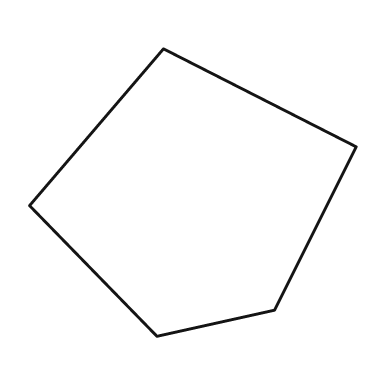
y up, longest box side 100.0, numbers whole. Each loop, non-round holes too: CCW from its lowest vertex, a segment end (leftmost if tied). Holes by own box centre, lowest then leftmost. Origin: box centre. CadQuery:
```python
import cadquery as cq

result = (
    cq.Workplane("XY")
    .moveTo(-11.0, -44.0)
    .lineTo(25.0, -36.0)
    .lineTo(50.0, 14.0)
    .lineTo(-9.0, 44.0)
    .lineTo(-50.0, -4.0)
    .close()
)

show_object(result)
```